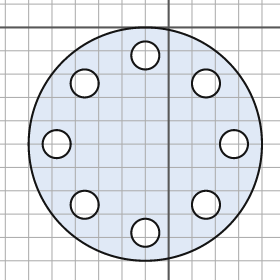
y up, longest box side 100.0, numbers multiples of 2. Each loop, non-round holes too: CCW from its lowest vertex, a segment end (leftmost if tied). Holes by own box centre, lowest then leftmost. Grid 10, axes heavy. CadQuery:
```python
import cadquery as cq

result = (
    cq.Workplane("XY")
    .moveTo(-10.0, -50.0)
    .circle(50.0)
    .moveTo(-10.0, -88.0)
    .circle(6.0)
    .moveTo(-36.0, -76.0)
    .circle(6.0)
    .moveTo(16.0, -76.0)
    .circle(6.0)
    .moveTo(-48.0, -50.0)
    .circle(6.0)
    .moveTo(28.0, -50.0)
    .circle(6.0)
    .moveTo(-36.0, -24.0)
    .circle(6.0)
    .moveTo(16.0, -24.0)
    .circle(6.0)
    .moveTo(-10.0, -12.0)
    .circle(6.0)
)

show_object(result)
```